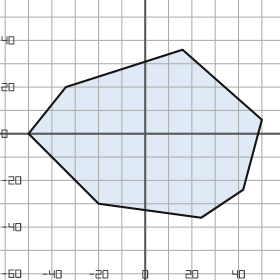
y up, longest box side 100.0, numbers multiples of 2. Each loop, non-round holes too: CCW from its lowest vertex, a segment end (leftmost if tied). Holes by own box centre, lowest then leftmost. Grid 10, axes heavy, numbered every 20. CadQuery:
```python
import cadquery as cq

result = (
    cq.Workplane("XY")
    .moveTo(24.0, -36.0)
    .lineTo(42.0, -24.0)
    .lineTo(50.0, 6.0)
    .lineTo(16.0, 36.0)
    .lineTo(-34.0, 20.0)
    .lineTo(-50.0, 0.0)
    .lineTo(-20.0, -30.0)
    .close()
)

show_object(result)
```